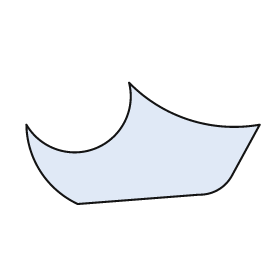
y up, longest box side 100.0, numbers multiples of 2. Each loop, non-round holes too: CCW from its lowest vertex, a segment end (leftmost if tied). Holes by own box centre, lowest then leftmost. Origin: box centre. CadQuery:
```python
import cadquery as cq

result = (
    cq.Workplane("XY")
    .moveTo(-28.0, -26.0)
    .lineTo(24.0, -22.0)
    .threePointArc((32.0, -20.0), (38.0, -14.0))
    .lineTo(50.0, 8.0)
    .threePointArc((20.0, 10.0), (-6.0, 26.0))
    .threePointArc((-20.0, -2.0), (-50.0, 8.0))
    .threePointArc((-44.0, -12.0), (-28.0, -26.0))
    .close()
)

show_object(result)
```